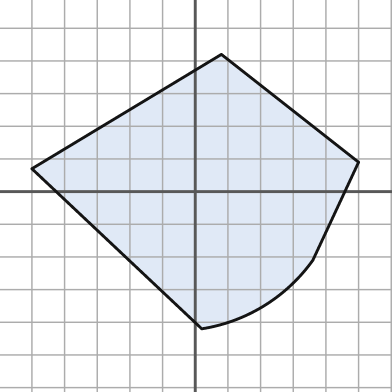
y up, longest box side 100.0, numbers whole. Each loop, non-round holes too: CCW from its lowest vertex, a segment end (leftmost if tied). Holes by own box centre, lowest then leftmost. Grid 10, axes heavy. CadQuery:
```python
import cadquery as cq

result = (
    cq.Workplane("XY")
    .moveTo(2.0, -42.0)
    .threePointArc((21.0, -35.0), (36.0, -21.0))
    .lineTo(50.0, 9.0)
    .lineTo(8.0, 42.0)
    .lineTo(-50.0, 7.0)
    .close()
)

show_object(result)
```